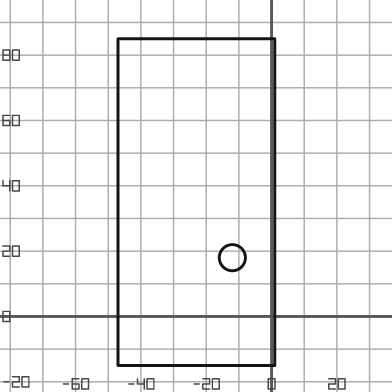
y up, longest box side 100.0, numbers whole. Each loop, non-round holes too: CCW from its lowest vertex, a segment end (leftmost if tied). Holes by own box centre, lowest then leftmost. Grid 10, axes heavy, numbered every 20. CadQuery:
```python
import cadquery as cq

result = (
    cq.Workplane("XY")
    .moveTo(-47.0, -15.0)
    .lineTo(1.0, -15.0)
    .lineTo(1.0, 85.0)
    .lineTo(-47.0, 85.0)
    .close()
    .moveTo(-12.0, 18.0)
    .circle(4.0)
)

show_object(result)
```